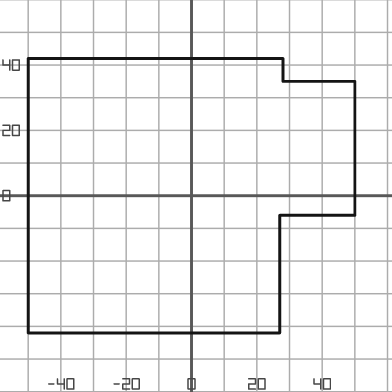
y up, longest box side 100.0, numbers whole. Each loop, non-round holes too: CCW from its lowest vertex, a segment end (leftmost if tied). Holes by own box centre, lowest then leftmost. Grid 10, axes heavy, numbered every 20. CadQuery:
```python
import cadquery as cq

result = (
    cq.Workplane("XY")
    .moveTo(-50.0, -42.0)
    .lineTo(27.0, -42.0)
    .lineTo(27.0, -6.0)
    .lineTo(50.0, -6.0)
    .lineTo(50.0, 35.0)
    .lineTo(28.0, 35.0)
    .lineTo(28.0, 42.0)
    .lineTo(-50.0, 42.0)
    .close()
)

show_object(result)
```